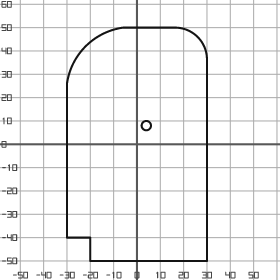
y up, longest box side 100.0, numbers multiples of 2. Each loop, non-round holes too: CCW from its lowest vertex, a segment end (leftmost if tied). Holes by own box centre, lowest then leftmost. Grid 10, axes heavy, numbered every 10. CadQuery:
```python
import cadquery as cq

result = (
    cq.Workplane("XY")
    .moveTo(-20.0, -50.0)
    .lineTo(30.0, -50.0)
    .lineTo(30.0, 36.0)
    .threePointArc((26.0, 46.0), (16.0, 50.0))
    .lineTo(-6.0, 50.0)
    .threePointArc((-22.0, 42.0), (-30.0, 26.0))
    .lineTo(-30.0, -40.0)
    .lineTo(-20.0, -40.0)
    .close()
    .moveTo(4.0, 8.0)
    .circle(2.0)
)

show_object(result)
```